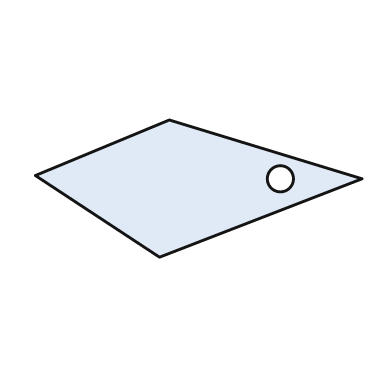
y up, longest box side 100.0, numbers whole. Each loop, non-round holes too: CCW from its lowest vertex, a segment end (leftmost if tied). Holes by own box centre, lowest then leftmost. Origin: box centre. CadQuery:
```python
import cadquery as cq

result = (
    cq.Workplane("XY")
    .moveTo(-12.0, -21.0)
    .lineTo(50.0, 3.0)
    .lineTo(-9.0, 21.0)
    .lineTo(-50.0, 4.0)
    .close()
    .moveTo(25.0, 3.0)
    .circle(4.0)
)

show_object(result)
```